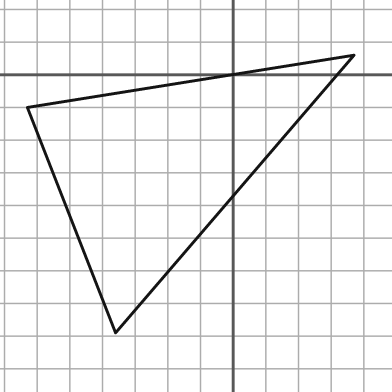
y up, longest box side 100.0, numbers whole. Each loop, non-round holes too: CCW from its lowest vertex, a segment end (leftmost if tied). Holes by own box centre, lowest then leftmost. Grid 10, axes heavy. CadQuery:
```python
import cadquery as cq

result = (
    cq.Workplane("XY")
    .moveTo(-36.0, -79.0)
    .lineTo(37.0, 6.0)
    .lineTo(-63.0, -10.0)
    .close()
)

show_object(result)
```